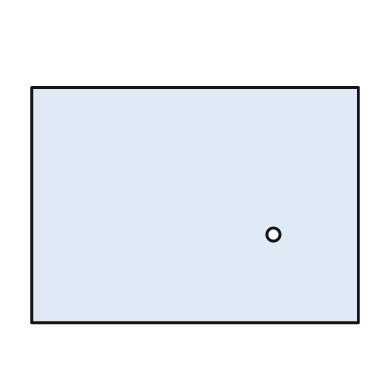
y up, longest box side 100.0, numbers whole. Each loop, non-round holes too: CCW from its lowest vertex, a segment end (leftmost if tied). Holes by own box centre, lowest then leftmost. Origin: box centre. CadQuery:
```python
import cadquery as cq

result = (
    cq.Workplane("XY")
    .moveTo(-50.0, -36.0)
    .lineTo(50.0, -36.0)
    .lineTo(50.0, 36.0)
    .lineTo(-50.0, 36.0)
    .close()
    .moveTo(24.0, -9.0)
    .circle(2.0)
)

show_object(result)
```